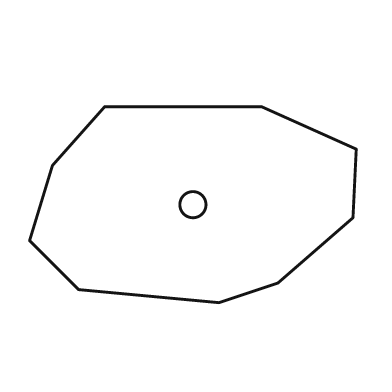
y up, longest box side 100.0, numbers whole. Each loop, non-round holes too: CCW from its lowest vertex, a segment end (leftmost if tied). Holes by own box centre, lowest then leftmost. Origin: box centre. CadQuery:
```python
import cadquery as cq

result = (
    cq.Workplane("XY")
    .moveTo(8.0, -30.0)
    .lineTo(26.0, -24.0)
    .lineTo(49.0, -4.0)
    .lineTo(50.0, 17.0)
    .lineTo(21.0, 30.0)
    .lineTo(-27.0, 30.0)
    .lineTo(-43.0, 12.0)
    .lineTo(-50.0, -11.0)
    .lineTo(-35.0, -26.0)
    .close()
    .moveTo(0.0, 0.0)
    .circle(4.0)
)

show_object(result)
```